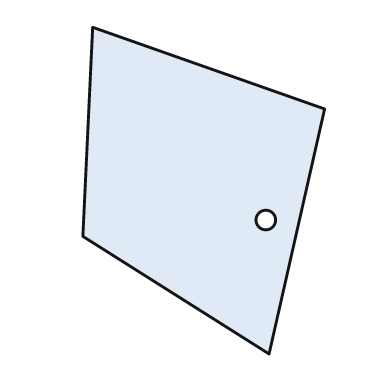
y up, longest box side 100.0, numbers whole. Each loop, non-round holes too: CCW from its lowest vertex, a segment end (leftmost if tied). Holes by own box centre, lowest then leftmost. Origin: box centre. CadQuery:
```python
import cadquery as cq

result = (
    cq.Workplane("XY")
    .moveTo(20.0, -50.0)
    .lineTo(37.0, 25.0)
    .lineTo(-34.0, 50.0)
    .lineTo(-37.0, -14.0)
    .close()
    .moveTo(19.0, -9.0)
    .circle(3.0)
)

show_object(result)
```